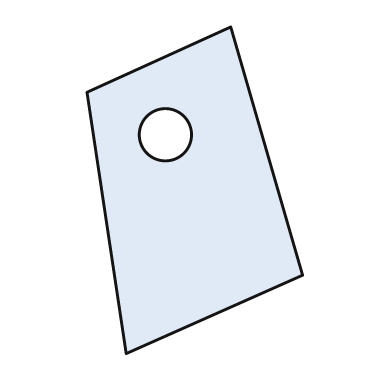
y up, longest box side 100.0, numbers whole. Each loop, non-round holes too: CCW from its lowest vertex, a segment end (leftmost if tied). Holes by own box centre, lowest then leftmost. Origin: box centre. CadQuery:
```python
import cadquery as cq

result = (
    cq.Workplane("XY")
    .moveTo(-21.0, -50.0)
    .lineTo(33.0, -26.0)
    .lineTo(11.0, 50.0)
    .lineTo(-33.0, 30.0)
    .close()
    .moveTo(-9.0, 17.0)
    .circle(8.0)
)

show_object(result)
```